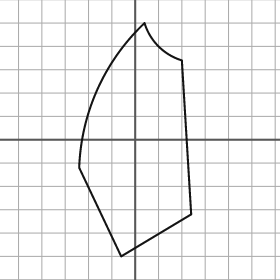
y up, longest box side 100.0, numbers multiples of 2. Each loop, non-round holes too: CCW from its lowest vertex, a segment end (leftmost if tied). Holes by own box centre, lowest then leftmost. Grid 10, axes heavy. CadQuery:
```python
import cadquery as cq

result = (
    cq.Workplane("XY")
    .moveTo(-6.0, -50.0)
    .lineTo(24.0, -32.0)
    .lineTo(20.0, 34.0)
    .threePointArc((10.0, 40.0), (4.0, 50.0))
    .threePointArc((-16.0, 22.0), (-24.0, -12.0))
    .close()
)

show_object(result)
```